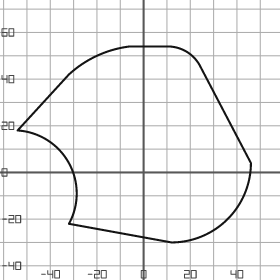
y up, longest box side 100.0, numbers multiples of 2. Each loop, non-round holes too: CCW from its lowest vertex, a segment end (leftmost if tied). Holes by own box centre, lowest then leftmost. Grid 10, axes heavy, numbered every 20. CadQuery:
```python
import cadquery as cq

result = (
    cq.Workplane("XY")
    .moveTo(12.0, -30.0)
    .threePointArc((36.0, -20.0), (46.0, 4.0))
    .lineTo(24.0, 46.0)
    .threePointArc((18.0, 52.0), (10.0, 54.0))
    .lineTo(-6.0, 54.0)
    .threePointArc((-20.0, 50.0), (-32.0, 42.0))
    .lineTo(-54.0, 18.0)
    .threePointArc((-32.0, 4.0), (-32.0, -22.0))
    .close()
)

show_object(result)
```